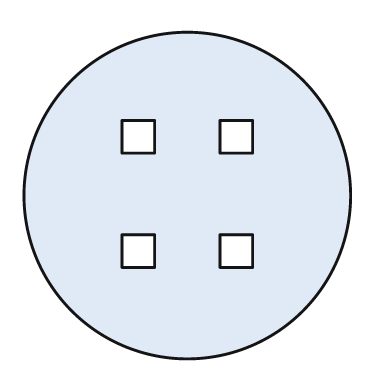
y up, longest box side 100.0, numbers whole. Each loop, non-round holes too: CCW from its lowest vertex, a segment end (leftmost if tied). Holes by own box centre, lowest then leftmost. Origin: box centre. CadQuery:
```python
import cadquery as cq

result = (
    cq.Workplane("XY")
    .moveTo(0.0, 0.0)
    .circle(50.0)
    .moveTo(-20.0, -22.0)
    .lineTo(-10.0, -22.0)
    .lineTo(-10.0, -12.0)
    .lineTo(-20.0, -12.0)
    .close()
    .moveTo(10.0, -22.0)
    .lineTo(20.0, -22.0)
    .lineTo(20.0, -12.0)
    .lineTo(10.0, -12.0)
    .close()
    .moveTo(-20.0, 13.0)
    .lineTo(-10.0, 13.0)
    .lineTo(-10.0, 23.0)
    .lineTo(-20.0, 23.0)
    .close()
    .moveTo(10.0, 13.0)
    .lineTo(20.0, 13.0)
    .lineTo(20.0, 23.0)
    .lineTo(10.0, 23.0)
    .close()
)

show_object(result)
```